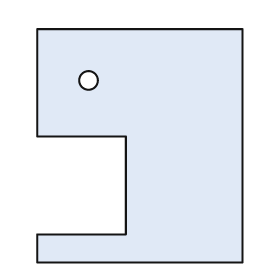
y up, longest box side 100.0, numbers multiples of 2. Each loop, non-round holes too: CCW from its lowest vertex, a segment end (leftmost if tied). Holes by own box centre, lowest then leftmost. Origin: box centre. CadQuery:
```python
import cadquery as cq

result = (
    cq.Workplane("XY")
    .moveTo(-44.0, -50.0)
    .lineTo(44.0, -50.0)
    .lineTo(44.0, 50.0)
    .lineTo(-44.0, 50.0)
    .lineTo(-44.0, 4.0)
    .lineTo(-6.0, 4.0)
    .lineTo(-6.0, -38.0)
    .lineTo(-44.0, -38.0)
    .close()
    .moveTo(-22.0, 28.0)
    .circle(4.0)
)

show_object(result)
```